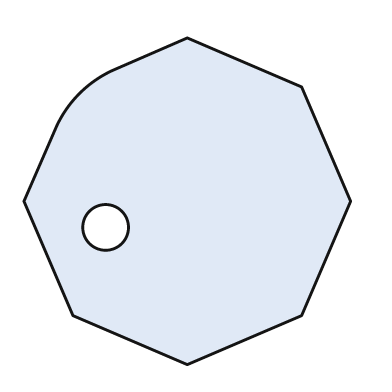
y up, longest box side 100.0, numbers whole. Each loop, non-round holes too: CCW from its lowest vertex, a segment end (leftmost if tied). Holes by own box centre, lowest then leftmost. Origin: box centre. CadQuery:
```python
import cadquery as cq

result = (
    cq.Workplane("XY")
    .moveTo(0.0, -50.0)
    .lineTo(35.0, -35.0)
    .lineTo(50.0, 0.0)
    .lineTo(35.0, 35.0)
    .lineTo(0.0, 50.0)
    .lineTo(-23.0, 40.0)
    .threePointArc((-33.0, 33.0), (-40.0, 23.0))
    .lineTo(-50.0, 0.0)
    .lineTo(-35.0, -35.0)
    .close()
    .moveTo(-25.0, -8.0)
    .circle(7.0)
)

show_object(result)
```